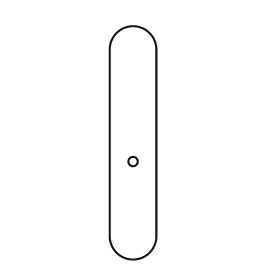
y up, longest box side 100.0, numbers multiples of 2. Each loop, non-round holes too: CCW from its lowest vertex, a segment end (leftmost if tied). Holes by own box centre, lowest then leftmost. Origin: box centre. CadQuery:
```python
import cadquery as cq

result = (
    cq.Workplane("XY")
    .moveTo(-10.0, -40.0)
    .threePointArc((0.0, -50.0), (10.0, -40.0))
    .lineTo(10.0, 40.0)
    .threePointArc((0.0, 50.0), (-10.0, 40.0))
    .close()
    .moveTo(0.0, -8.0)
    .circle(2.0)
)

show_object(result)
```